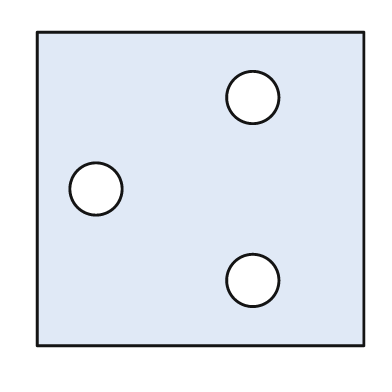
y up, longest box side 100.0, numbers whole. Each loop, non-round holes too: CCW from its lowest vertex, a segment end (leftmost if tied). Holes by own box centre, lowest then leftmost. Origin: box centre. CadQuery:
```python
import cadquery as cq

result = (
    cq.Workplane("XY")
    .moveTo(-50.0, -48.0)
    .lineTo(50.0, -48.0)
    .lineTo(50.0, 48.0)
    .lineTo(-50.0, 48.0)
    .close()
    .moveTo(16.0, -28.0)
    .circle(8.0)
    .moveTo(-32.0, 0.0)
    .circle(8.0)
    .moveTo(16.0, 28.0)
    .circle(8.0)
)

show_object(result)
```